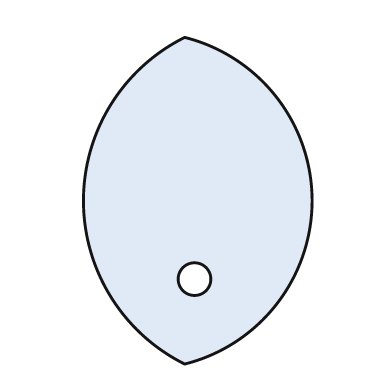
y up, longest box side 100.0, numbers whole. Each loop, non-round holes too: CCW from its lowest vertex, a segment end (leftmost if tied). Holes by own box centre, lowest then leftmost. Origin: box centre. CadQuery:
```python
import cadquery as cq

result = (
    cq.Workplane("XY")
    .moveTo(-4.0, -50.0)
    .threePointArc((35.0, 0.0), (-4.0, 50.0))
    .threePointArc((-35.0, 0.0), (-4.0, -50.0))
    .close()
    .moveTo(-1.0, -24.0)
    .circle(5.0)
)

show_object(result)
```